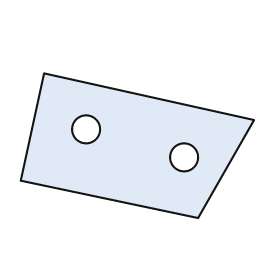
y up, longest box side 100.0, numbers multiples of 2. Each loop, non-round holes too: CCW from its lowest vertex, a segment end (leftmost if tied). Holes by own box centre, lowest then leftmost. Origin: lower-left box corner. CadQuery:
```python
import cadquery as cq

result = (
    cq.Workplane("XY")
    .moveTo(76.0, 0.0)
    .lineTo(100.0, 42.0)
    .lineTo(10.0, 62.0)
    .lineTo(0.0, 16.0)
    .close()
    .moveTo(70.0, 26.0)
    .circle(6.0)
    .moveTo(28.0, 38.0)
    .circle(6.0)
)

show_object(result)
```